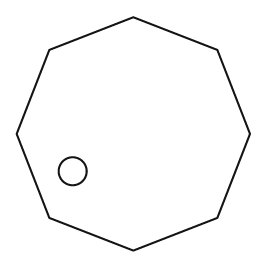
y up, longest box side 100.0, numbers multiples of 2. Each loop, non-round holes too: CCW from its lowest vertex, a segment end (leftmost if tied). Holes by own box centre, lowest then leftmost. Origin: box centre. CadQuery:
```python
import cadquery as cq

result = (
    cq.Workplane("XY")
    .moveTo(0.0, -50.0)
    .lineTo(36.0, -36.0)
    .lineTo(50.0, 0.0)
    .lineTo(36.0, 36.0)
    .lineTo(0.0, 50.0)
    .lineTo(-36.0, 36.0)
    .lineTo(-50.0, 0.0)
    .lineTo(-36.0, -36.0)
    .close()
    .moveTo(-26.0, -16.0)
    .circle(6.0)
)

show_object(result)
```